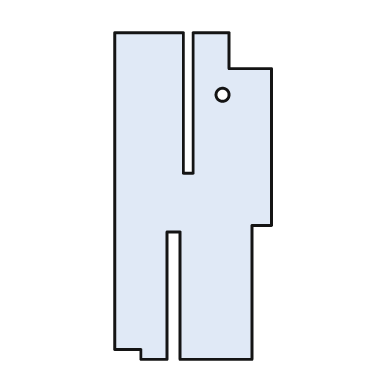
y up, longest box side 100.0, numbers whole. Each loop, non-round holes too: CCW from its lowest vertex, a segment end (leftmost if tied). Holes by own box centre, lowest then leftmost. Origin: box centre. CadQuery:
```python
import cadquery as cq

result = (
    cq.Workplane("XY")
    .moveTo(-16.0, -50.0)
    .lineTo(-8.0, -50.0)
    .lineTo(-8.0, -11.0)
    .lineTo(-4.0, -11.0)
    .lineTo(-4.0, -50.0)
    .lineTo(18.0, -50.0)
    .lineTo(18.0, -9.0)
    .lineTo(24.0, -9.0)
    .lineTo(24.0, 39.0)
    .lineTo(11.0, 39.0)
    .lineTo(11.0, 50.0)
    .lineTo(0.0, 50.0)
    .lineTo(0.0, 7.0)
    .lineTo(-3.0, 7.0)
    .lineTo(-3.0, 50.0)
    .lineTo(-24.0, 50.0)
    .lineTo(-24.0, -47.0)
    .lineTo(-16.0, -47.0)
    .close()
    .moveTo(9.0, 31.0)
    .circle(2.0)
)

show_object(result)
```